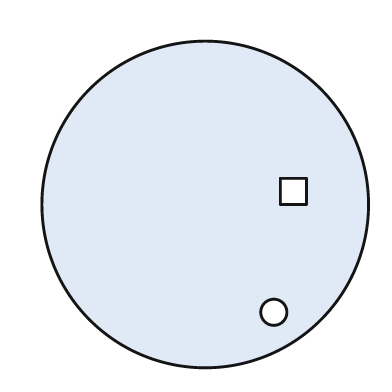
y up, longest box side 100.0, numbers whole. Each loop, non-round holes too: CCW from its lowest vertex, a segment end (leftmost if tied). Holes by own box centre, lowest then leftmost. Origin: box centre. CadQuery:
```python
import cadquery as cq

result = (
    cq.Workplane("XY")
    .moveTo(0.0, 0.0)
    .circle(50.0)
    .moveTo(21.0, -33.0)
    .circle(4.0)
    .moveTo(23.0, 0.0)
    .lineTo(31.0, 0.0)
    .lineTo(31.0, 8.0)
    .lineTo(23.0, 8.0)
    .close()
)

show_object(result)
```